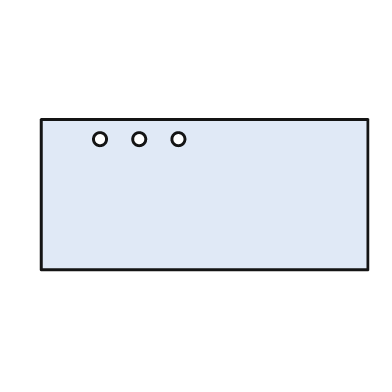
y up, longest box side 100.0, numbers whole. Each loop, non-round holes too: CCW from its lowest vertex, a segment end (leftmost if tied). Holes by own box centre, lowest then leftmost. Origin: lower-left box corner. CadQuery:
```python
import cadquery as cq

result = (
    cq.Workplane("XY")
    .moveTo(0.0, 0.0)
    .lineTo(100.0, 0.0)
    .lineTo(100.0, 46.0)
    .lineTo(0.0, 46.0)
    .close()
    .moveTo(18.0, 40.0)
    .circle(2.0)
    .moveTo(30.0, 40.0)
    .circle(2.0)
    .moveTo(42.0, 40.0)
    .circle(2.0)
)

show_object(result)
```